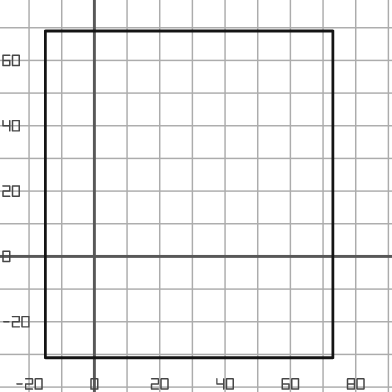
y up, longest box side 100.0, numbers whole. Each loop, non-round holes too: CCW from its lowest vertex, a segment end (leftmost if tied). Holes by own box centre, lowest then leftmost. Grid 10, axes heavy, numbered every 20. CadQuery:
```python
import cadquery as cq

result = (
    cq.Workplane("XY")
    .moveTo(-15.0, -31.0)
    .lineTo(73.0, -31.0)
    .lineTo(73.0, 69.0)
    .lineTo(-15.0, 69.0)
    .close()
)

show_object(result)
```